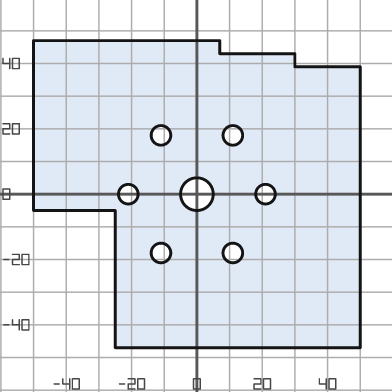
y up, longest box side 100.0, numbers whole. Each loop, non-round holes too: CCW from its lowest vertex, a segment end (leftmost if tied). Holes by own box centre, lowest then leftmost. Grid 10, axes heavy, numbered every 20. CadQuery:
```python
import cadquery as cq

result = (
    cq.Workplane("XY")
    .moveTo(-25.0, -47.0)
    .lineTo(50.0, -47.0)
    .lineTo(50.0, 39.0)
    .lineTo(30.0, 39.0)
    .lineTo(30.0, 43.0)
    .lineTo(7.0, 43.0)
    .lineTo(7.0, 47.0)
    .lineTo(-50.0, 47.0)
    .lineTo(-50.0, -5.0)
    .lineTo(-25.0, -5.0)
    .close()
    .moveTo(-11.0, -18.0)
    .circle(3.0)
    .moveTo(11.0, -18.0)
    .circle(3.0)
    .moveTo(-21.0, 0.0)
    .circle(3.0)
    .moveTo(0.0, 0.0)
    .circle(5.0)
    .moveTo(21.0, 0.0)
    .circle(3.0)
    .moveTo(-11.0, 18.0)
    .circle(3.0)
    .moveTo(11.0, 18.0)
    .circle(3.0)
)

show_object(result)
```